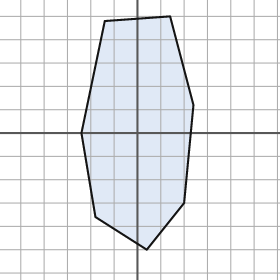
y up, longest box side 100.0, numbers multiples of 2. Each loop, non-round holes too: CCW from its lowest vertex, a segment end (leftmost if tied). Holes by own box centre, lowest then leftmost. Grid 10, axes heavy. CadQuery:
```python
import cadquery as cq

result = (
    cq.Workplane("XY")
    .moveTo(4.0, -50.0)
    .lineTo(20.0, -30.0)
    .lineTo(24.0, 12.0)
    .lineTo(14.0, 50.0)
    .lineTo(-14.0, 48.0)
    .lineTo(-24.0, 0.0)
    .lineTo(-18.0, -36.0)
    .close()
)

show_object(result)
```